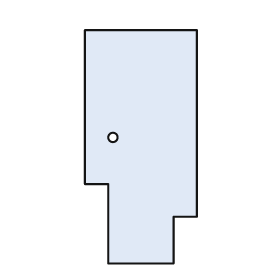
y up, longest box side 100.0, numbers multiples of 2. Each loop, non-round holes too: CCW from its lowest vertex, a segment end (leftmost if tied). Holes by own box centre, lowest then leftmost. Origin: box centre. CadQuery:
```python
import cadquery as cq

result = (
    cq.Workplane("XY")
    .moveTo(-14.0, -50.0)
    .lineTo(14.0, -50.0)
    .lineTo(14.0, -30.0)
    .lineTo(24.0, -30.0)
    .lineTo(24.0, 50.0)
    .lineTo(-24.0, 50.0)
    .lineTo(-24.0, -16.0)
    .lineTo(-14.0, -16.0)
    .close()
    .moveTo(-12.0, 4.0)
    .circle(2.0)
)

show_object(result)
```